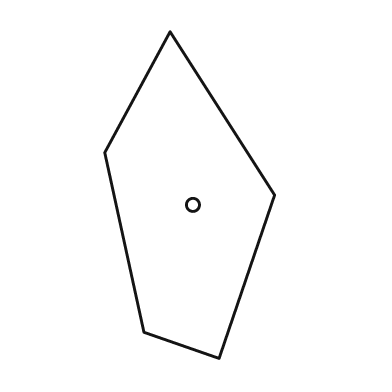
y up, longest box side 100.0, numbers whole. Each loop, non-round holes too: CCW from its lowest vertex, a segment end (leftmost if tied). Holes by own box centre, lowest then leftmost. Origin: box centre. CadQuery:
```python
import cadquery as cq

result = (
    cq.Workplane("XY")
    .moveTo(9.0, -50.0)
    .lineTo(26.0, 0.0)
    .lineTo(-6.0, 50.0)
    .lineTo(-26.0, 13.0)
    .lineTo(-14.0, -42.0)
    .close()
    .moveTo(1.0, -3.0)
    .circle(2.0)
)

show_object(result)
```